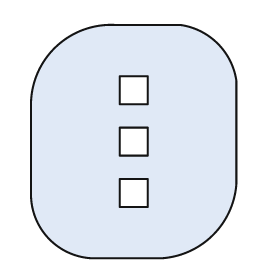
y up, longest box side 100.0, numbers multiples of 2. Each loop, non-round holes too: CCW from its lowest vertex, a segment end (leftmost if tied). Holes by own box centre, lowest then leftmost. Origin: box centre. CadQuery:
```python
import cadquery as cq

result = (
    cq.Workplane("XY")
    .moveTo(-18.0, -50.0)
    .lineTo(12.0, -50.0)
    .threePointArc((34.0, -40.0), (44.0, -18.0))
    .lineTo(44.0, 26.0)
    .threePointArc((36.0, 42.0), (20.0, 50.0))
    .lineTo(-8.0, 50.0)
    .threePointArc((-34.0, 40.0), (-44.0, 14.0))
    .lineTo(-44.0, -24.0)
    .threePointArc((-36.0, -42.0), (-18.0, -50.0))
    .close()
    .moveTo(-6.0, -28.0)
    .lineTo(6.0, -28.0)
    .lineTo(6.0, -16.0)
    .lineTo(-6.0, -16.0)
    .close()
    .moveTo(-6.0, -6.0)
    .lineTo(6.0, -6.0)
    .lineTo(6.0, 6.0)
    .lineTo(-6.0, 6.0)
    .close()
    .moveTo(-6.0, 16.0)
    .lineTo(6.0, 16.0)
    .lineTo(6.0, 28.0)
    .lineTo(-6.0, 28.0)
    .close()
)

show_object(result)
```